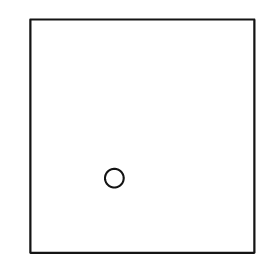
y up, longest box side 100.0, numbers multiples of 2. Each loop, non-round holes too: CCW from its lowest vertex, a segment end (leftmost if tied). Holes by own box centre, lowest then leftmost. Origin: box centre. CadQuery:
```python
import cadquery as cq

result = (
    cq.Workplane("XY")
    .moveTo(-48.0, -50.0)
    .lineTo(48.0, -50.0)
    .lineTo(48.0, 50.0)
    .lineTo(-48.0, 50.0)
    .close()
    .moveTo(-12.0, -18.0)
    .circle(4.0)
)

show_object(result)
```